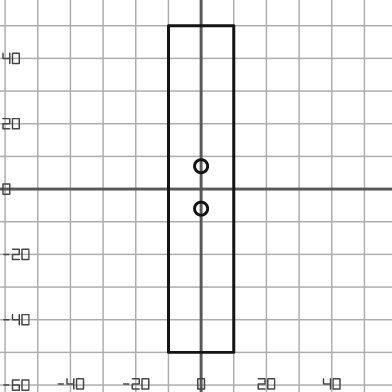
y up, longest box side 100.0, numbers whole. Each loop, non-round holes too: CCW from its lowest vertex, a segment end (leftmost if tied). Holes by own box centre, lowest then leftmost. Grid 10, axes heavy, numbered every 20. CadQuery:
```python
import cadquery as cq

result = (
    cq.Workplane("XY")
    .moveTo(-10.0, -50.0)
    .lineTo(10.0, -50.0)
    .lineTo(10.0, 50.0)
    .lineTo(-10.0, 50.0)
    .close()
    .moveTo(0.0, -6.0)
    .circle(2.0)
    .moveTo(0.0, 7.0)
    .circle(2.0)
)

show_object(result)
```